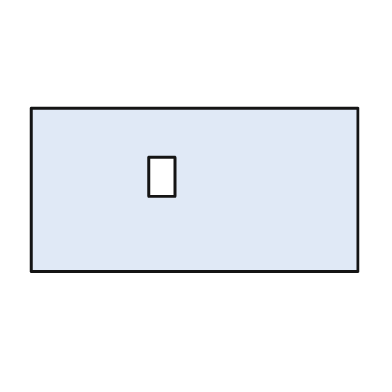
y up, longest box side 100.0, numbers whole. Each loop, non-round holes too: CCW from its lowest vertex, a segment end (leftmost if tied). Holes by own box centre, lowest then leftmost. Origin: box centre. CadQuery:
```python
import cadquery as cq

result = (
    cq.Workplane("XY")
    .moveTo(-50.0, -25.0)
    .lineTo(50.0, -25.0)
    .lineTo(50.0, 25.0)
    .lineTo(-50.0, 25.0)
    .close()
    .moveTo(-14.0, -2.0)
    .lineTo(-6.0, -2.0)
    .lineTo(-6.0, 10.0)
    .lineTo(-14.0, 10.0)
    .close()
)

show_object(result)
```